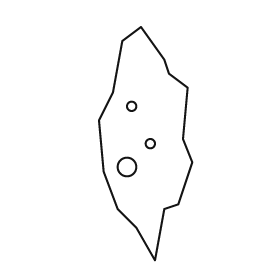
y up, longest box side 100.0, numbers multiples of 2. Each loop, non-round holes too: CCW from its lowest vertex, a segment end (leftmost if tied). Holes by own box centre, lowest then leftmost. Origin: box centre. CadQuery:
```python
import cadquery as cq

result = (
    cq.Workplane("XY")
    .moveTo(4.0, -50.0)
    .lineTo(8.0, -28.0)
    .lineTo(14.0, -26.0)
    .lineTo(20.0, -8.0)
    .lineTo(16.0, 2.0)
    .lineTo(18.0, 24.0)
    .lineTo(10.0, 30.0)
    .lineTo(8.0, 36.0)
    .lineTo(-2.0, 50.0)
    .lineTo(-10.0, 44.0)
    .lineTo(-14.0, 22.0)
    .lineTo(-20.0, 10.0)
    .lineTo(-18.0, -12.0)
    .lineTo(-12.0, -28.0)
    .lineTo(-4.0, -36.0)
    .close()
    .moveTo(-8.0, -10.0)
    .circle(4.0)
    .moveTo(2.0, 0.0)
    .circle(2.0)
    .moveTo(-6.0, 16.0)
    .circle(2.0)
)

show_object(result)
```